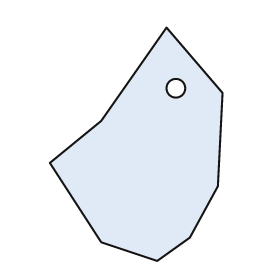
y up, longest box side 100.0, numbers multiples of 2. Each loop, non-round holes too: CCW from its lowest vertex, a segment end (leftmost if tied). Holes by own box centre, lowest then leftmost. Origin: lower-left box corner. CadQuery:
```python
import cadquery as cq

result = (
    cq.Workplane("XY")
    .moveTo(46.0, 0.0)
    .lineTo(60.0, 10.0)
    .lineTo(72.0, 32.0)
    .lineTo(74.0, 72.0)
    .lineTo(50.0, 100.0)
    .lineTo(22.0, 60.0)
    .lineTo(0.0, 42.0)
    .lineTo(22.0, 8.0)
    .close()
    .moveTo(54.0, 74.0)
    .circle(4.0)
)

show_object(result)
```